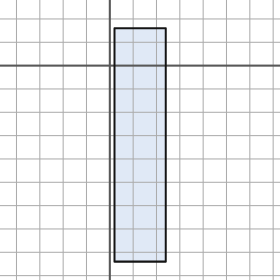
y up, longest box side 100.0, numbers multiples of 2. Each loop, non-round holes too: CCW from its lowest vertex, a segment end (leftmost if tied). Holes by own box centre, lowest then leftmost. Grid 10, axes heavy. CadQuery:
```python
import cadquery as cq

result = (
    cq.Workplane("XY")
    .moveTo(2.0, -84.0)
    .lineTo(24.0, -84.0)
    .lineTo(24.0, 16.0)
    .lineTo(2.0, 16.0)
    .close()
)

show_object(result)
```